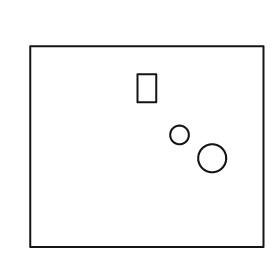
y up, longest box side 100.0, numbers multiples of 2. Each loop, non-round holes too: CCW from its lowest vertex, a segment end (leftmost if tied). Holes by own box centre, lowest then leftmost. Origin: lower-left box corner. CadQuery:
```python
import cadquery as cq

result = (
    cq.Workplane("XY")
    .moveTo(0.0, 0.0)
    .lineTo(100.0, 0.0)
    .lineTo(100.0, 86.0)
    .lineTo(0.0, 86.0)
    .close()
    .moveTo(78.0, 38.0)
    .circle(6.0)
    .moveTo(64.0, 48.0)
    .circle(4.0)
    .moveTo(46.0, 62.0)
    .lineTo(54.0, 62.0)
    .lineTo(54.0, 74.0)
    .lineTo(46.0, 74.0)
    .close()
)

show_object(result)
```